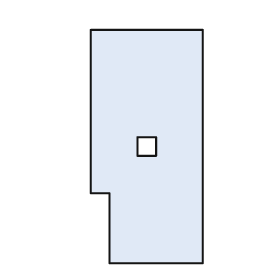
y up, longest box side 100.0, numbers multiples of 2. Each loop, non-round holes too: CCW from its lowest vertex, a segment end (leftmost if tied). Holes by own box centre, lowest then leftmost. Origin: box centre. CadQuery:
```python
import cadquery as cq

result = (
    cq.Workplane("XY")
    .moveTo(-16.0, -50.0)
    .lineTo(24.0, -50.0)
    .lineTo(24.0, 50.0)
    .lineTo(-24.0, 50.0)
    .lineTo(-24.0, -20.0)
    .lineTo(-16.0, -20.0)
    .close()
    .moveTo(-4.0, -4.0)
    .lineTo(4.0, -4.0)
    .lineTo(4.0, 4.0)
    .lineTo(-4.0, 4.0)
    .close()
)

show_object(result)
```